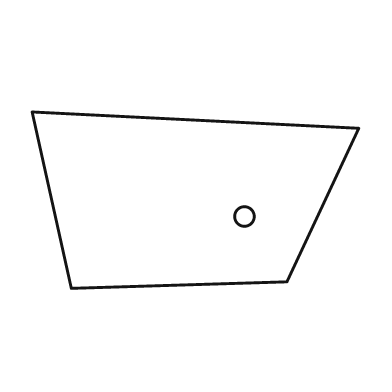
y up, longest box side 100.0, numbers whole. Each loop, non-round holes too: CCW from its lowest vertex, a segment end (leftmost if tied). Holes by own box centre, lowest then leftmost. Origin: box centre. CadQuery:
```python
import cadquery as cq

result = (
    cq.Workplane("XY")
    .moveTo(-38.0, -27.0)
    .lineTo(28.0, -25.0)
    .lineTo(50.0, 22.0)
    .lineTo(-50.0, 27.0)
    .close()
    .moveTo(15.0, -5.0)
    .circle(3.0)
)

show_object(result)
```